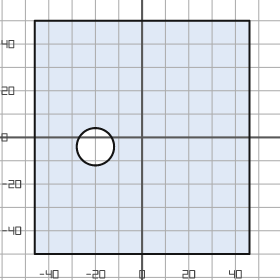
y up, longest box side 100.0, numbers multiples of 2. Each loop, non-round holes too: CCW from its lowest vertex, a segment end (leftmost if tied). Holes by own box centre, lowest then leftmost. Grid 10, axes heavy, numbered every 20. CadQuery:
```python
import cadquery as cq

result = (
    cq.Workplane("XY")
    .moveTo(-46.0, -50.0)
    .lineTo(46.0, -50.0)
    .lineTo(46.0, 50.0)
    .lineTo(-46.0, 50.0)
    .close()
    .moveTo(-20.0, -4.0)
    .circle(8.0)
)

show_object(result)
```